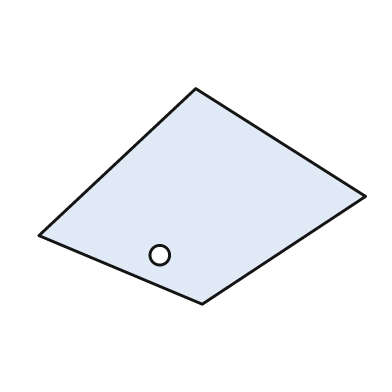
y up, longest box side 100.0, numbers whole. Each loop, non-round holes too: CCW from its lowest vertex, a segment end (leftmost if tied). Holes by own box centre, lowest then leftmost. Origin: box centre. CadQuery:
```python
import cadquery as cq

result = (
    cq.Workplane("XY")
    .moveTo(0.0, -33.0)
    .lineTo(50.0, 0.0)
    .lineTo(-2.0, 33.0)
    .lineTo(-50.0, -12.0)
    .close()
    .moveTo(-13.0, -18.0)
    .circle(3.0)
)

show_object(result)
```